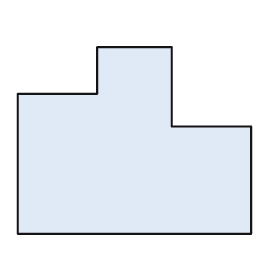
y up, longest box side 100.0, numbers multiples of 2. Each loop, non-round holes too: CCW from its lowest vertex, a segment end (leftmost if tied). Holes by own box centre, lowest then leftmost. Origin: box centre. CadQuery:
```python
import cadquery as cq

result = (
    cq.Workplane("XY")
    .moveTo(-50.0, -40.0)
    .lineTo(50.0, -40.0)
    .lineTo(50.0, 6.0)
    .lineTo(16.0, 6.0)
    .lineTo(16.0, 40.0)
    .lineTo(-16.0, 40.0)
    .lineTo(-16.0, 20.0)
    .lineTo(-50.0, 20.0)
    .close()
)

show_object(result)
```